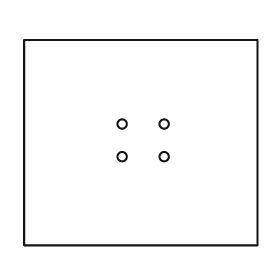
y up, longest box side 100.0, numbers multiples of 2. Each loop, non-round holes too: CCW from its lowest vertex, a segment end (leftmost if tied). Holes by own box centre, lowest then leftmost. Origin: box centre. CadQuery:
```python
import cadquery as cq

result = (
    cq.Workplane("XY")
    .moveTo(-50.0, -44.0)
    .lineTo(50.0, -44.0)
    .lineTo(50.0, 44.0)
    .lineTo(-50.0, 44.0)
    .close()
    .moveTo(-8.0, -6.0)
    .circle(2.0)
    .moveTo(10.0, -6.0)
    .circle(2.0)
    .moveTo(-8.0, 8.0)
    .circle(2.0)
    .moveTo(10.0, 8.0)
    .circle(2.0)
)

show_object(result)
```